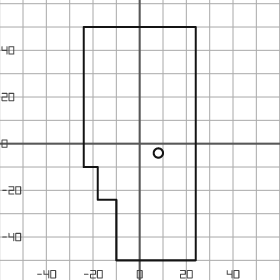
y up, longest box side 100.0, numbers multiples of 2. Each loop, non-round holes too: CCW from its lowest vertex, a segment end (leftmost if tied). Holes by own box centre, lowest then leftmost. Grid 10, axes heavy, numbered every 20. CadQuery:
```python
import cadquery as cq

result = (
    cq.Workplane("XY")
    .moveTo(-10.0, -50.0)
    .lineTo(24.0, -50.0)
    .lineTo(24.0, 50.0)
    .lineTo(-24.0, 50.0)
    .lineTo(-24.0, -10.0)
    .lineTo(-18.0, -10.0)
    .lineTo(-18.0, -24.0)
    .lineTo(-10.0, -24.0)
    .close()
    .moveTo(8.0, -4.0)
    .circle(2.0)
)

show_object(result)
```